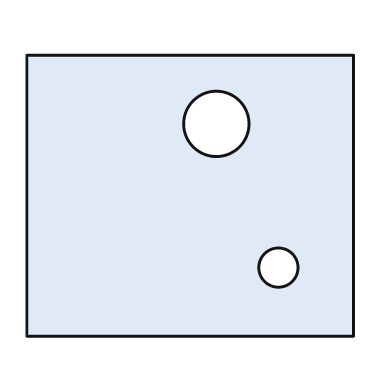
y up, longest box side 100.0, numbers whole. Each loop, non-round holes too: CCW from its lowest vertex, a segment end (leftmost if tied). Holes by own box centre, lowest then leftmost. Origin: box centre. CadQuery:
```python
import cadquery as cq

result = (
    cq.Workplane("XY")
    .moveTo(-50.0, -43.0)
    .lineTo(50.0, -43.0)
    .lineTo(50.0, 43.0)
    .lineTo(-50.0, 43.0)
    .close()
    .moveTo(27.0, -22.0)
    .circle(6.0)
    .moveTo(8.0, 22.0)
    .circle(10.0)
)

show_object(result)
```